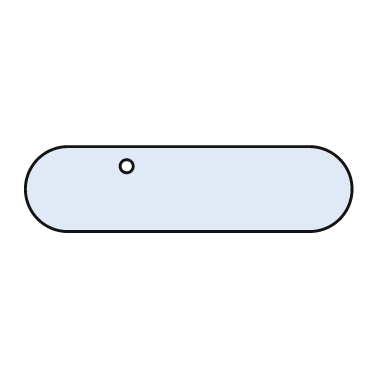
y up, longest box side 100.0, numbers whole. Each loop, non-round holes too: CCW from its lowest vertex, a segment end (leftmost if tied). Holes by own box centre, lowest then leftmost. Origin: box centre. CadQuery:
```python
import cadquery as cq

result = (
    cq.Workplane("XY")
    .moveTo(-37.0, -13.0)
    .lineTo(37.0, -13.0)
    .threePointArc((50.0, 0.0), (37.0, 13.0))
    .lineTo(-37.0, 13.0)
    .threePointArc((-50.0, 0.0), (-37.0, -13.0))
    .close()
    .moveTo(-19.0, 7.0)
    .circle(2.0)
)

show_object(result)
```